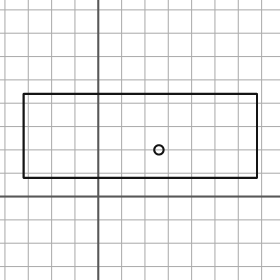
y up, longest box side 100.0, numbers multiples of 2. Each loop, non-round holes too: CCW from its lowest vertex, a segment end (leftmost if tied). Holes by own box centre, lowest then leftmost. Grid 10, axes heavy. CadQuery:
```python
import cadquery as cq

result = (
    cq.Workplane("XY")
    .moveTo(-32.0, 8.0)
    .lineTo(68.0, 8.0)
    .lineTo(68.0, 44.0)
    .lineTo(-32.0, 44.0)
    .close()
    .moveTo(26.0, 20.0)
    .circle(2.0)
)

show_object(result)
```